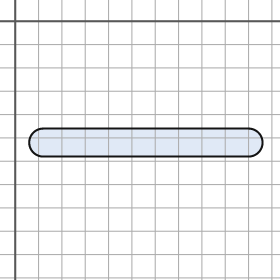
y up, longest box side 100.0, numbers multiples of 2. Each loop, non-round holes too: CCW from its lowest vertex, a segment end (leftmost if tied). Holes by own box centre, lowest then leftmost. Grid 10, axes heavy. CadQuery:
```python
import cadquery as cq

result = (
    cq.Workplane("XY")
    .moveTo(12.0, -58.0)
    .lineTo(100.0, -58.0)
    .threePointArc((106.0, -52.0), (100.0, -46.0))
    .lineTo(12.0, -46.0)
    .threePointArc((6.0, -52.0), (12.0, -58.0))
    .close()
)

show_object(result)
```